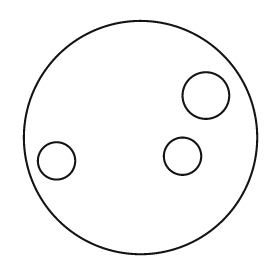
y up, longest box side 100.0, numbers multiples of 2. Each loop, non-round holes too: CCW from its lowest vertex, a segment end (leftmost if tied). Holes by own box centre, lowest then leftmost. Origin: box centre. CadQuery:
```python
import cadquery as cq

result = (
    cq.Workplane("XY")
    .moveTo(0.0, 0.0)
    .circle(50.0)
    .moveTo(-36.0, -10.0)
    .circle(8.0)
    .moveTo(18.0, -8.0)
    .circle(8.0)
    .moveTo(28.0, 18.0)
    .circle(10.0)
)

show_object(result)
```